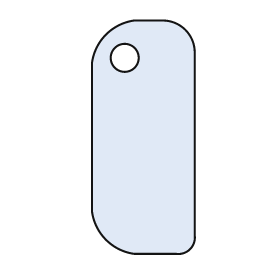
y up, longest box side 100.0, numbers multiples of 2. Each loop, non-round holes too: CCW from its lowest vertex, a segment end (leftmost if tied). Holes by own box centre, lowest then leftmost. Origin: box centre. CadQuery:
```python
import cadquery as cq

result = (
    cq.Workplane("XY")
    .moveTo(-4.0, -50.0)
    .lineTo(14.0, -50.0)
    .threePointArc((20.0, -48.0), (22.0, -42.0))
    .lineTo(22.0, 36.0)
    .threePointArc((18.0, 46.0), (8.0, 50.0))
    .lineTo(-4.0, 50.0)
    .threePointArc((-16.0, 44.0), (-22.0, 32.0))
    .lineTo(-22.0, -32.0)
    .threePointArc((-16.0, -44.0), (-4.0, -50.0))
    .close()
    .moveTo(-8.0, 34.0)
    .circle(6.0)
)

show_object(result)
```